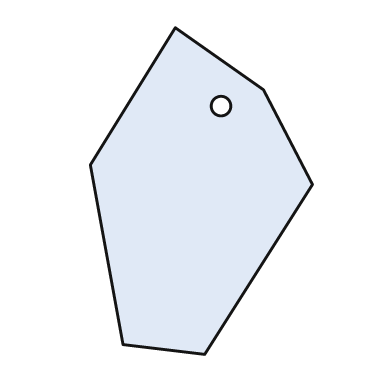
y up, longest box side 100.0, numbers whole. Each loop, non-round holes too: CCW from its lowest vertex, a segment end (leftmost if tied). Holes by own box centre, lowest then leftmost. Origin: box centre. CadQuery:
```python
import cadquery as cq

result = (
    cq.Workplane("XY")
    .moveTo(1.0, -50.0)
    .lineTo(34.0, 2.0)
    .lineTo(19.0, 31.0)
    .lineTo(-8.0, 50.0)
    .lineTo(-34.0, 8.0)
    .lineTo(-24.0, -47.0)
    .close()
    .moveTo(6.0, 26.0)
    .circle(3.0)
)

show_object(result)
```